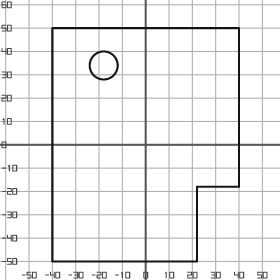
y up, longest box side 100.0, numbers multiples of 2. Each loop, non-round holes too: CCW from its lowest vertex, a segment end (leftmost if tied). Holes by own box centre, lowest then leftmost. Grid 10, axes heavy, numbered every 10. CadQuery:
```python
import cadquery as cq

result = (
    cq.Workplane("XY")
    .moveTo(-40.0, -50.0)
    .lineTo(22.0, -50.0)
    .lineTo(22.0, -18.0)
    .lineTo(40.0, -18.0)
    .lineTo(40.0, 50.0)
    .lineTo(-40.0, 50.0)
    .close()
    .moveTo(-18.0, 34.0)
    .circle(6.0)
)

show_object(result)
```